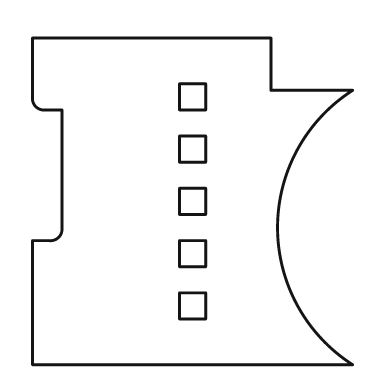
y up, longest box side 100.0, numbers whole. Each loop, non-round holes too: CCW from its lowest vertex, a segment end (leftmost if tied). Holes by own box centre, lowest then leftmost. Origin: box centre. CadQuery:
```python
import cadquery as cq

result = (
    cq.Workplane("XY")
    .moveTo(-49.0, -50.0)
    .lineTo(49.0, -50.0)
    .threePointArc((26.0, -8.0), (49.0, 34.0))
    .lineTo(24.0, 34.0)
    .lineTo(24.0, 50.0)
    .lineTo(-49.0, 50.0)
    .lineTo(-49.0, 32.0)
    .threePointArc((-48.0, 29.0), (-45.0, 28.0))
    .lineTo(-40.0, 28.0)
    .lineTo(-40.0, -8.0)
    .threePointArc((-41.0, -11.0), (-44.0, -12.0))
    .lineTo(-49.0, -12.0)
    .close()
    .moveTo(-4.0, -36.0)
    .lineTo(4.0, -36.0)
    .lineTo(4.0, -28.0)
    .lineTo(-4.0, -28.0)
    .close()
    .moveTo(-4.0, -20.0)
    .lineTo(4.0, -20.0)
    .lineTo(4.0, -12.0)
    .lineTo(-4.0, -12.0)
    .close()
    .moveTo(-4.0, -4.0)
    .lineTo(4.0, -4.0)
    .lineTo(4.0, 4.0)
    .lineTo(-4.0, 4.0)
    .close()
    .moveTo(-4.0, 12.0)
    .lineTo(4.0, 12.0)
    .lineTo(4.0, 20.0)
    .lineTo(-4.0, 20.0)
    .close()
    .moveTo(-4.0, 28.0)
    .lineTo(4.0, 28.0)
    .lineTo(4.0, 36.0)
    .lineTo(-4.0, 36.0)
    .close()
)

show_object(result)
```